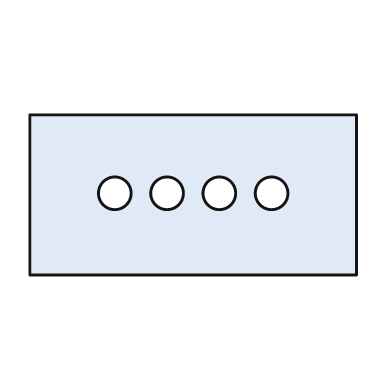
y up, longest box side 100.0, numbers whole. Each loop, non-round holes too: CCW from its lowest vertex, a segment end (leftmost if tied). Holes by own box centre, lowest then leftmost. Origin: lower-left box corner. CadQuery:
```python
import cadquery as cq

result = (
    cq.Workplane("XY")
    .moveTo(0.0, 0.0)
    .lineTo(100.0, 0.0)
    .lineTo(100.0, 49.0)
    .lineTo(0.0, 49.0)
    .close()
    .moveTo(26.0, 25.0)
    .circle(5.0)
    .moveTo(42.0, 25.0)
    .circle(5.0)
    .moveTo(58.0, 25.0)
    .circle(5.0)
    .moveTo(74.0, 25.0)
    .circle(5.0)
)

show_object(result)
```